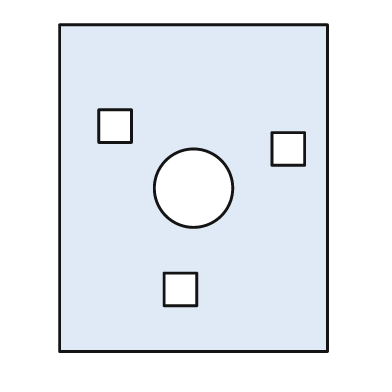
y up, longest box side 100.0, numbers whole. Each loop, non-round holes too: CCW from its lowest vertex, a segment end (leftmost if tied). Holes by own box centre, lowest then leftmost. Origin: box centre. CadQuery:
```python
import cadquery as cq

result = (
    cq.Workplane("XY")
    .moveTo(-41.0, -50.0)
    .lineTo(41.0, -50.0)
    .lineTo(41.0, 50.0)
    .lineTo(-41.0, 50.0)
    .close()
    .moveTo(-9.0, -36.0)
    .lineTo(1.0, -36.0)
    .lineTo(1.0, -26.0)
    .lineTo(-9.0, -26.0)
    .close()
    .moveTo(0.0, 0.0)
    .circle(12.0)
    .moveTo(24.0, 7.0)
    .lineTo(34.0, 7.0)
    .lineTo(34.0, 17.0)
    .lineTo(24.0, 17.0)
    .close()
    .moveTo(-29.0, 14.0)
    .lineTo(-19.0, 14.0)
    .lineTo(-19.0, 24.0)
    .lineTo(-29.0, 24.0)
    .close()
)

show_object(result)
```